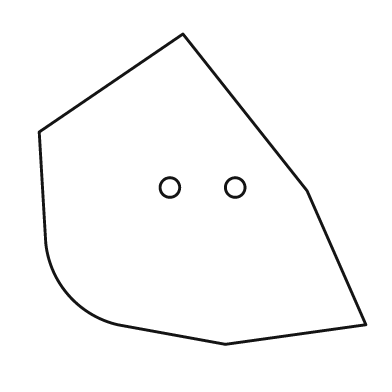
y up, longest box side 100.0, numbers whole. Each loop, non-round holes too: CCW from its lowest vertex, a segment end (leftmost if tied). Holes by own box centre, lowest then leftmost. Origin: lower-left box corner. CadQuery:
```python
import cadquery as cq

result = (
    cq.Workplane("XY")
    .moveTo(57.0, 0.0)
    .lineTo(100.0, 6.0)
    .lineTo(82.0, 47.0)
    .lineTo(44.0, 95.0)
    .lineTo(0.0, 65.0)
    .lineTo(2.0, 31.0)
    .threePointArc((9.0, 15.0), (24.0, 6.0))
    .close()
    .moveTo(40.0, 48.0)
    .circle(3.0)
    .moveTo(60.0, 48.0)
    .circle(3.0)
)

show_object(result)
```